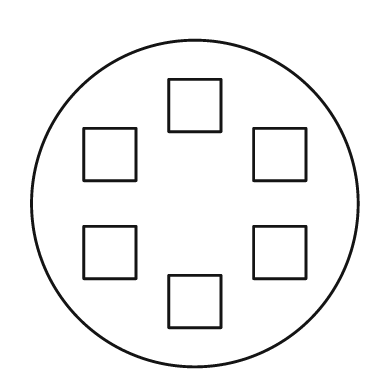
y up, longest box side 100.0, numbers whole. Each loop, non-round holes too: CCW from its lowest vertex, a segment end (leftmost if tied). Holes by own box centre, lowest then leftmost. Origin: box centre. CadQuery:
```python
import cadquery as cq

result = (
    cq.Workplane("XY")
    .moveTo(0.0, 0.0)
    .circle(50.0)
    .moveTo(-8.0, -38.0)
    .lineTo(8.0, -38.0)
    .lineTo(8.0, -22.0)
    .lineTo(-8.0, -22.0)
    .close()
    .moveTo(-34.0, -23.0)
    .lineTo(-18.0, -23.0)
    .lineTo(-18.0, -7.0)
    .lineTo(-34.0, -7.0)
    .close()
    .moveTo(18.0, -23.0)
    .lineTo(34.0, -23.0)
    .lineTo(34.0, -7.0)
    .lineTo(18.0, -7.0)
    .close()
    .moveTo(-34.0, 7.0)
    .lineTo(-18.0, 7.0)
    .lineTo(-18.0, 23.0)
    .lineTo(-34.0, 23.0)
    .close()
    .moveTo(18.0, 7.0)
    .lineTo(34.0, 7.0)
    .lineTo(34.0, 23.0)
    .lineTo(18.0, 23.0)
    .close()
    .moveTo(-8.0, 22.0)
    .lineTo(8.0, 22.0)
    .lineTo(8.0, 38.0)
    .lineTo(-8.0, 38.0)
    .close()
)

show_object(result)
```